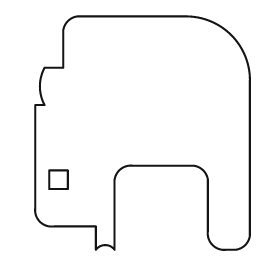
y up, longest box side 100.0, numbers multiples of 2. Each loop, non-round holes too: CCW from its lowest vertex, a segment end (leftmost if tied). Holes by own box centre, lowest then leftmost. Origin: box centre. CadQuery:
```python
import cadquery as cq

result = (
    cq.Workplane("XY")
    .moveTo(-20.0, -50.0)
    .threePointArc((-16.0, -48.0), (-12.0, -50.0))
    .lineTo(-12.0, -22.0)
    .threePointArc((-10.0, -16.0), (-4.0, -14.0))
    .lineTo(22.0, -14.0)
    .threePointArc((26.0, -16.0), (28.0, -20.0))
    .lineTo(28.0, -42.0)
    .threePointArc((30.0, -48.0), (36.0, -50.0))
    .lineTo(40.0, -50.0)
    .threePointArc((44.0, -48.0), (46.0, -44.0))
    .lineTo(46.0, 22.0)
    .threePointArc((38.0, 42.0), (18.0, 50.0))
    .lineTo(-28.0, 50.0)
    .threePointArc((-32.0, 48.0), (-34.0, 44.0))
    .lineTo(-34.0, 28.0)
    .lineTo(-42.0, 28.0)
    .threePointArc((-44.0, 20.0), (-42.0, 12.0))
    .lineTo(-46.0, 12.0)
    .lineTo(-46.0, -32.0)
    .threePointArc((-44.0, -38.0), (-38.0, -40.0))
    .lineTo(-20.0, -40.0)
    .close()
    .moveTo(-40.0, -24.0)
    .lineTo(-32.0, -24.0)
    .lineTo(-32.0, -16.0)
    .lineTo(-40.0, -16.0)
    .close()
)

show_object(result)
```